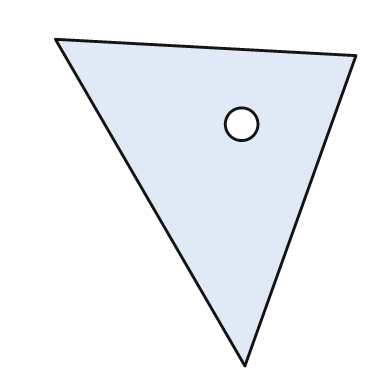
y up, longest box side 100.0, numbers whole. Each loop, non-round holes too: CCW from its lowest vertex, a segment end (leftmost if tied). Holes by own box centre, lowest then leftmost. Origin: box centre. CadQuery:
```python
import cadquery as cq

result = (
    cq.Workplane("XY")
    .moveTo(12.0, -50.0)
    .lineTo(46.0, 45.0)
    .lineTo(-46.0, 50.0)
    .close()
    .moveTo(11.0, 24.0)
    .circle(5.0)
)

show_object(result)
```